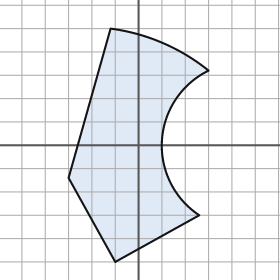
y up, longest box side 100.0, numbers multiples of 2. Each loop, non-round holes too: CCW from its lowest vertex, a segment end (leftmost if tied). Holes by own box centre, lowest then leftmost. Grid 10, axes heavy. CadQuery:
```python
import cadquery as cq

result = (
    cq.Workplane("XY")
    .moveTo(-10.0, -50.0)
    .lineTo(26.0, -30.0)
    .threePointArc((10.0, 2.0), (30.0, 32.0))
    .threePointArc((10.0, 44.0), (-12.0, 50.0))
    .lineTo(-30.0, -14.0)
    .close()
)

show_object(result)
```